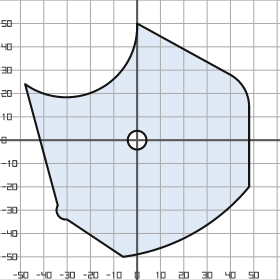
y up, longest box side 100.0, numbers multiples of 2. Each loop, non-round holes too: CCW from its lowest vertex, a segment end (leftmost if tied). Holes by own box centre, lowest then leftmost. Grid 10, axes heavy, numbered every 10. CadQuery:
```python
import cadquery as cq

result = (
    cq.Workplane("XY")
    .moveTo(-6.0, -50.0)
    .threePointArc((24.0, -40.0), (48.0, -20.0))
    .lineTo(48.0, 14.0)
    .threePointArc((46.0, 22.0), (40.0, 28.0))
    .lineTo(0.0, 50.0)
    .threePointArc((-16.0, 22.0), (-48.0, 24.0))
    .lineTo(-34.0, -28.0)
    .threePointArc((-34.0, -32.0), (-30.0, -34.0))
    .close()
    .moveTo(0.0, 0.0)
    .circle(4.0)
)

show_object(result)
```